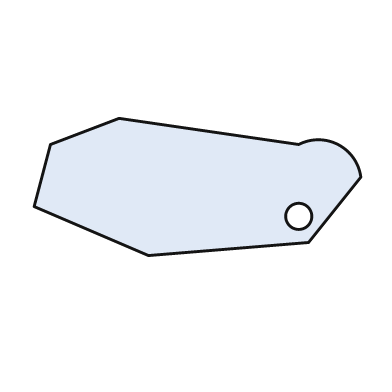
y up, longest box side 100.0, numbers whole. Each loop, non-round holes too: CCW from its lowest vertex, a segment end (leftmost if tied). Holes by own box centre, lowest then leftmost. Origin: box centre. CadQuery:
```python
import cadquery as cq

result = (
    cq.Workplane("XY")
    .moveTo(-15.0, -21.0)
    .lineTo(34.0, -17.0)
    .lineTo(50.0, 3.0)
    .threePointArc((43.0, 13.0), (31.0, 13.0))
    .lineTo(-24.0, 21.0)
    .lineTo(-45.0, 13.0)
    .lineTo(-50.0, -6.0)
    .close()
    .moveTo(31.0, -9.0)
    .circle(4.0)
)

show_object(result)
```